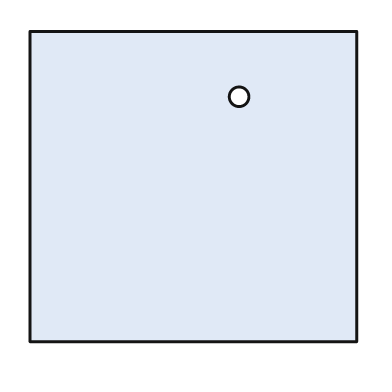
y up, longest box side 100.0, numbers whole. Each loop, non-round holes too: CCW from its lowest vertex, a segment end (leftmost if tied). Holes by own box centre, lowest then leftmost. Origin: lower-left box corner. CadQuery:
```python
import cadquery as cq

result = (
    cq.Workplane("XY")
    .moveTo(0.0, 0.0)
    .lineTo(100.0, 0.0)
    .lineTo(100.0, 95.0)
    .lineTo(0.0, 95.0)
    .close()
    .moveTo(64.0, 75.0)
    .circle(3.0)
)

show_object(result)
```